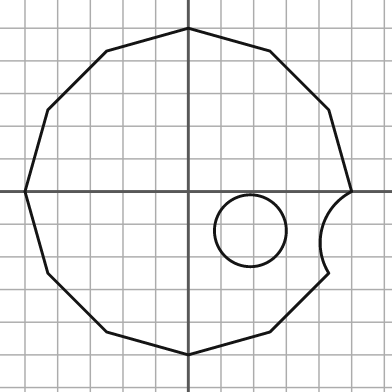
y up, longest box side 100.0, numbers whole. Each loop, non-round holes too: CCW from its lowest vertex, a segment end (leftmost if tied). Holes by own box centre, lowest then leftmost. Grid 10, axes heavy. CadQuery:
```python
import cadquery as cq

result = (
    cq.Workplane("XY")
    .moveTo(0.0, -50.0)
    .lineTo(25.0, -43.0)
    .lineTo(43.0, -25.0)
    .threePointArc((41.0, -11.0), (50.0, 0.0))
    .lineTo(43.0, 25.0)
    .lineTo(25.0, 43.0)
    .lineTo(0.0, 50.0)
    .lineTo(-25.0, 43.0)
    .lineTo(-43.0, 25.0)
    .lineTo(-50.0, 0.0)
    .lineTo(-43.0, -25.0)
    .lineTo(-25.0, -43.0)
    .close()
    .moveTo(19.0, -12.0)
    .circle(11.0)
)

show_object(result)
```